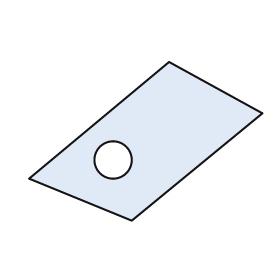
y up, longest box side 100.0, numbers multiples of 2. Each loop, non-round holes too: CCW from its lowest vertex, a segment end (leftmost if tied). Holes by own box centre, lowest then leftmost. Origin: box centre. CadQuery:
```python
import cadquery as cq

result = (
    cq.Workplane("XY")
    .moveTo(-6.0, -34.0)
    .lineTo(50.0, 12.0)
    .lineTo(10.0, 34.0)
    .lineTo(-50.0, -16.0)
    .close()
    .moveTo(-14.0, -8.0)
    .circle(8.0)
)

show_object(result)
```